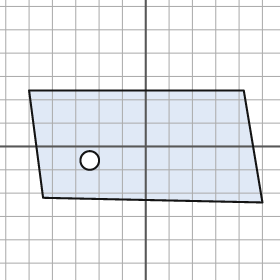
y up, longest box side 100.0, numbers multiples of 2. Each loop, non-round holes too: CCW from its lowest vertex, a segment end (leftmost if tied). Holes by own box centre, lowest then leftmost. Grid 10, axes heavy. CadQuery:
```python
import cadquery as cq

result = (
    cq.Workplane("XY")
    .moveTo(50.0, -24.0)
    .lineTo(42.0, 24.0)
    .lineTo(-50.0, 24.0)
    .lineTo(-44.0, -22.0)
    .close()
    .moveTo(-24.0, -6.0)
    .circle(4.0)
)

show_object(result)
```